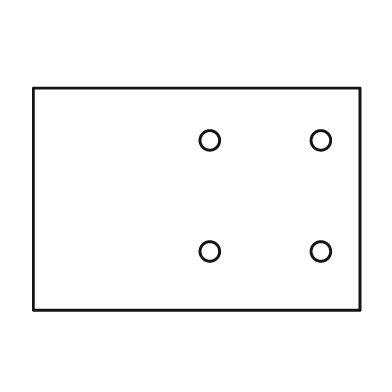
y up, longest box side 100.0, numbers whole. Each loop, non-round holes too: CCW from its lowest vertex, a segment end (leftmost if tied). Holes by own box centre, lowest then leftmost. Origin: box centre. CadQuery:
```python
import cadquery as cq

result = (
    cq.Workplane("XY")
    .moveTo(-50.0, -34.0)
    .lineTo(50.0, -34.0)
    .lineTo(50.0, 34.0)
    .lineTo(-50.0, 34.0)
    .close()
    .moveTo(4.0, -16.0)
    .circle(3.0)
    .moveTo(38.0, -16.0)
    .circle(3.0)
    .moveTo(4.0, 18.0)
    .circle(3.0)
    .moveTo(38.0, 18.0)
    .circle(3.0)
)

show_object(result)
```